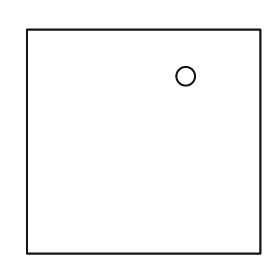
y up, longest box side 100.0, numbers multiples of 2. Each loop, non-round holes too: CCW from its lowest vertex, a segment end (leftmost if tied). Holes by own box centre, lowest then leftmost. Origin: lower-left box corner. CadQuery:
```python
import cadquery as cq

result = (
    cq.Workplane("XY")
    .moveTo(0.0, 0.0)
    .lineTo(100.0, 0.0)
    .lineTo(100.0, 96.0)
    .lineTo(0.0, 96.0)
    .close()
    .moveTo(68.0, 76.0)
    .circle(4.0)
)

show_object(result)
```